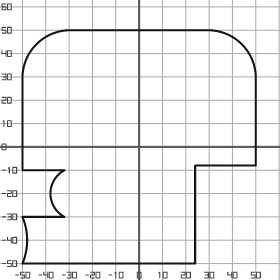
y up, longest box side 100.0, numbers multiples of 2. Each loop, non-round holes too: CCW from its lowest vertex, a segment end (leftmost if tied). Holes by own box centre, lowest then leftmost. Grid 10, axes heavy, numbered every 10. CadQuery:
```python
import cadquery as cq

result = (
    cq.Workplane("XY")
    .moveTo(-50.0, -50.0)
    .lineTo(24.0, -50.0)
    .lineTo(24.0, -8.0)
    .lineTo(50.0, -8.0)
    .lineTo(50.0, 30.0)
    .threePointArc((44.0, 44.0), (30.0, 50.0))
    .lineTo(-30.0, 50.0)
    .threePointArc((-44.0, 44.0), (-50.0, 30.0))
    .lineTo(-50.0, -10.0)
    .lineTo(-32.0, -10.0)
    .threePointArc((-38.0, -20.0), (-32.0, -30.0))
    .lineTo(-50.0, -30.0)
    .threePointArc((-48.0, -40.0), (-50.0, -50.0))
    .close()
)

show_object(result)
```